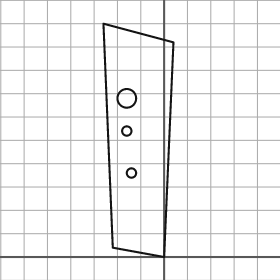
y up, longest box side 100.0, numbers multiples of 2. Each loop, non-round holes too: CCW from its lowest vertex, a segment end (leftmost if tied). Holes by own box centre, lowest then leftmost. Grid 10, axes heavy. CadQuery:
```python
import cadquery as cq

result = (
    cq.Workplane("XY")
    .moveTo(0.0, 0.0)
    .lineTo(4.0, 92.0)
    .lineTo(-26.0, 100.0)
    .lineTo(-22.0, 4.0)
    .close()
    .moveTo(-14.0, 36.0)
    .circle(2.0)
    .moveTo(-16.0, 54.0)
    .circle(2.0)
    .moveTo(-16.0, 68.0)
    .circle(4.0)
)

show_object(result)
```